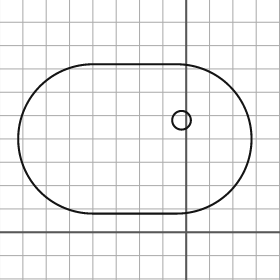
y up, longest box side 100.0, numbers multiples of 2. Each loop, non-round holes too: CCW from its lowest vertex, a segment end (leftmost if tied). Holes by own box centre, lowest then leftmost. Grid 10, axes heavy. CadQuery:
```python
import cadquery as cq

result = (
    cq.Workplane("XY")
    .moveTo(-40.0, 8.0)
    .lineTo(-4.0, 8.0)
    .threePointArc((28.0, 40.0), (-4.0, 72.0))
    .lineTo(-40.0, 72.0)
    .threePointArc((-72.0, 40.0), (-40.0, 8.0))
    .close()
    .moveTo(-2.0, 48.0)
    .circle(4.0)
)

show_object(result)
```